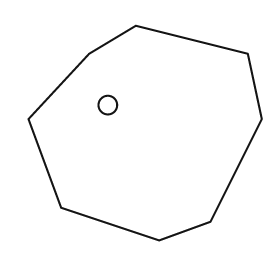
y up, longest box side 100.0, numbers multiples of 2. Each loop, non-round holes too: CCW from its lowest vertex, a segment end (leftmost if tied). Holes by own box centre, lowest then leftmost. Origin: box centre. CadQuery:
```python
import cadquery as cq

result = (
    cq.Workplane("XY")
    .moveTo(6.0, -46.0)
    .lineTo(28.0, -38.0)
    .lineTo(50.0, 6.0)
    .lineTo(44.0, 34.0)
    .lineTo(-4.0, 46.0)
    .lineTo(-24.0, 34.0)
    .lineTo(-50.0, 6.0)
    .lineTo(-36.0, -32.0)
    .close()
    .moveTo(-16.0, 12.0)
    .circle(4.0)
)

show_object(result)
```